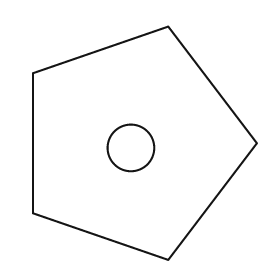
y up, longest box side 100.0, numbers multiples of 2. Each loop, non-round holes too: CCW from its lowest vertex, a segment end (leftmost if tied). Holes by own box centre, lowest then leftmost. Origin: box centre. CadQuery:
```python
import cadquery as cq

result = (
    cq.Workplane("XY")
    .moveTo(10.0, -50.0)
    .lineTo(48.0, 0.0)
    .lineTo(10.0, 50.0)
    .lineTo(-48.0, 30.0)
    .lineTo(-48.0, -30.0)
    .close()
    .moveTo(-6.0, -2.0)
    .circle(10.0)
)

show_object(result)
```